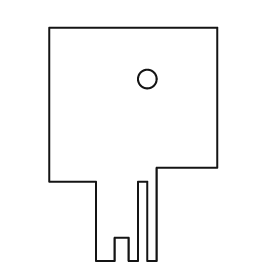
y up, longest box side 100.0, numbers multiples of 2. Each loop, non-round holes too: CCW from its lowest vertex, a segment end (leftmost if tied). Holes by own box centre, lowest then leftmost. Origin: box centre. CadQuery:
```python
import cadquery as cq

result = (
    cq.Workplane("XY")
    .moveTo(-16.0, -50.0)
    .lineTo(-8.0, -50.0)
    .lineTo(-8.0, -40.0)
    .lineTo(-2.0, -40.0)
    .lineTo(-2.0, -50.0)
    .lineTo(2.0, -50.0)
    .lineTo(2.0, -16.0)
    .lineTo(6.0, -16.0)
    .lineTo(6.0, -50.0)
    .lineTo(10.0, -50.0)
    .lineTo(10.0, -10.0)
    .lineTo(36.0, -10.0)
    .lineTo(36.0, 50.0)
    .lineTo(-36.0, 50.0)
    .lineTo(-36.0, -16.0)
    .lineTo(-16.0, -16.0)
    .close()
    .moveTo(6.0, 28.0)
    .circle(4.0)
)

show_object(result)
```